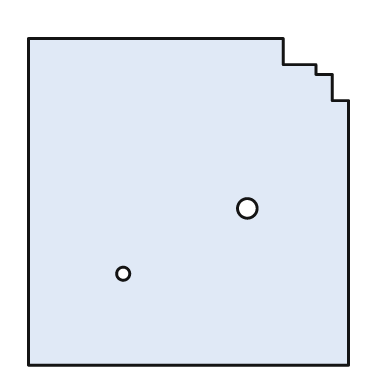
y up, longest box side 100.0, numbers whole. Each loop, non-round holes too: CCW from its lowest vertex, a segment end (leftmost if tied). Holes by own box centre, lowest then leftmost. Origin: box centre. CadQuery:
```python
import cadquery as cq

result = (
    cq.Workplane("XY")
    .moveTo(-49.0, -50.0)
    .lineTo(49.0, -50.0)
    .lineTo(49.0, 31.0)
    .lineTo(44.0, 31.0)
    .lineTo(44.0, 39.0)
    .lineTo(39.0, 39.0)
    .lineTo(39.0, 42.0)
    .lineTo(29.0, 42.0)
    .lineTo(29.0, 50.0)
    .lineTo(-49.0, 50.0)
    .close()
    .moveTo(-20.0, -22.0)
    .circle(2.0)
    .moveTo(18.0, -2.0)
    .circle(3.0)
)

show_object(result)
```